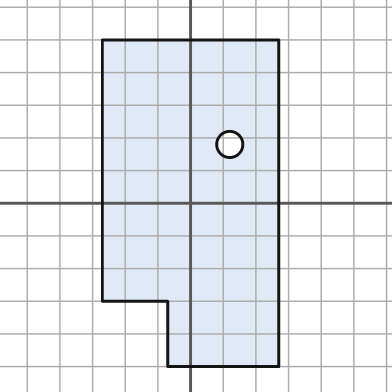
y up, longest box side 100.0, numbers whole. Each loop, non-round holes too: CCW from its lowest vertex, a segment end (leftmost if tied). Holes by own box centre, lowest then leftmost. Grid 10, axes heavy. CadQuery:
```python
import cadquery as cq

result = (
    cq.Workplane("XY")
    .moveTo(-7.0, -50.0)
    .lineTo(27.0, -50.0)
    .lineTo(27.0, 50.0)
    .lineTo(-27.0, 50.0)
    .lineTo(-27.0, -30.0)
    .lineTo(-7.0, -30.0)
    .close()
    .moveTo(12.0, 18.0)
    .circle(4.0)
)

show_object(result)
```